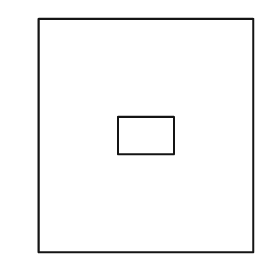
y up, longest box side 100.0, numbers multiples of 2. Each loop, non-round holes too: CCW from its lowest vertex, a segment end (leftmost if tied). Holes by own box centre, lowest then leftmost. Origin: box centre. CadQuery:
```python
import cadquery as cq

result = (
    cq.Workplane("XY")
    .moveTo(-46.0, -50.0)
    .lineTo(46.0, -50.0)
    .lineTo(46.0, 50.0)
    .lineTo(-46.0, 50.0)
    .close()
    .moveTo(-12.0, -8.0)
    .lineTo(12.0, -8.0)
    .lineTo(12.0, 8.0)
    .lineTo(-12.0, 8.0)
    .close()
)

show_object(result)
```